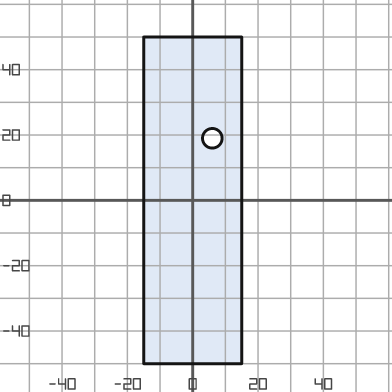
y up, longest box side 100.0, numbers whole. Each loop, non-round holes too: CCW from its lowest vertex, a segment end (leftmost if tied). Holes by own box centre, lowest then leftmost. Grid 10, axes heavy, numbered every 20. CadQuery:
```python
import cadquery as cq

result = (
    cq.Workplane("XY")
    .moveTo(-15.0, -50.0)
    .lineTo(15.0, -50.0)
    .lineTo(15.0, 50.0)
    .lineTo(-15.0, 50.0)
    .close()
    .moveTo(6.0, 19.0)
    .circle(3.0)
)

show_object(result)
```